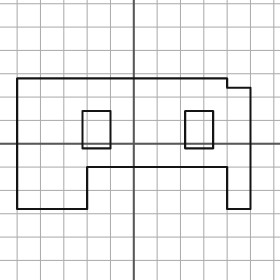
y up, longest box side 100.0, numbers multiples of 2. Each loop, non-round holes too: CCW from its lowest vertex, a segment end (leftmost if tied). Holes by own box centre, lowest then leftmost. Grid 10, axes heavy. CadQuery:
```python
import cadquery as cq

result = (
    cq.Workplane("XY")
    .moveTo(-50.0, -28.0)
    .lineTo(-20.0, -28.0)
    .lineTo(-20.0, -10.0)
    .lineTo(40.0, -10.0)
    .lineTo(40.0, -28.0)
    .lineTo(50.0, -28.0)
    .lineTo(50.0, 24.0)
    .lineTo(40.0, 24.0)
    .lineTo(40.0, 28.0)
    .lineTo(-50.0, 28.0)
    .close()
    .moveTo(-22.0, -2.0)
    .lineTo(-10.0, -2.0)
    .lineTo(-10.0, 14.0)
    .lineTo(-22.0, 14.0)
    .close()
    .moveTo(22.0, -2.0)
    .lineTo(34.0, -2.0)
    .lineTo(34.0, 14.0)
    .lineTo(22.0, 14.0)
    .close()
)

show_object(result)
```